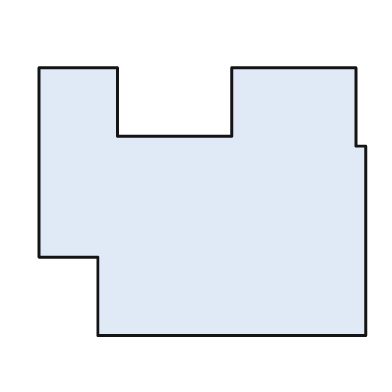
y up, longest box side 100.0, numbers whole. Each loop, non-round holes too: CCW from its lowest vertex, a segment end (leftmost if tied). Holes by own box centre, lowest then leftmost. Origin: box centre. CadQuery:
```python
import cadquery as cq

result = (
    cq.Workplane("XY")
    .moveTo(-32.0, -41.0)
    .lineTo(50.0, -41.0)
    .lineTo(50.0, 17.0)
    .lineTo(47.0, 17.0)
    .lineTo(47.0, 41.0)
    .lineTo(9.0, 41.0)
    .lineTo(9.0, 20.0)
    .lineTo(-26.0, 20.0)
    .lineTo(-26.0, 41.0)
    .lineTo(-50.0, 41.0)
    .lineTo(-50.0, -17.0)
    .lineTo(-32.0, -17.0)
    .close()
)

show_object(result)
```